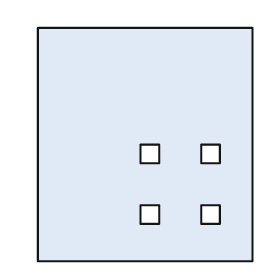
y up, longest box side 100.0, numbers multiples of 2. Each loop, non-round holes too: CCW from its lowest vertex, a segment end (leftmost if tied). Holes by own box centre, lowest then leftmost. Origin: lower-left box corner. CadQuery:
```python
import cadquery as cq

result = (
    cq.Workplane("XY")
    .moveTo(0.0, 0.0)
    .lineTo(92.0, 0.0)
    .lineTo(92.0, 100.0)
    .lineTo(0.0, 100.0)
    .close()
    .moveTo(44.0, 16.0)
    .lineTo(52.0, 16.0)
    .lineTo(52.0, 24.0)
    .lineTo(44.0, 24.0)
    .close()
    .moveTo(70.0, 16.0)
    .lineTo(78.0, 16.0)
    .lineTo(78.0, 24.0)
    .lineTo(70.0, 24.0)
    .close()
    .moveTo(44.0, 42.0)
    .lineTo(52.0, 42.0)
    .lineTo(52.0, 50.0)
    .lineTo(44.0, 50.0)
    .close()
    .moveTo(70.0, 42.0)
    .lineTo(78.0, 42.0)
    .lineTo(78.0, 50.0)
    .lineTo(70.0, 50.0)
    .close()
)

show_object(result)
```